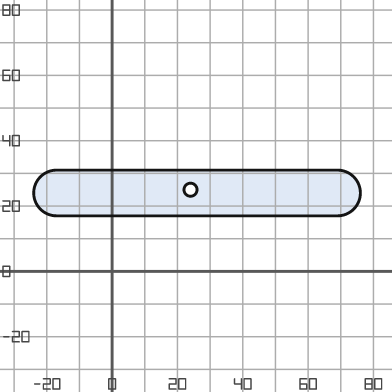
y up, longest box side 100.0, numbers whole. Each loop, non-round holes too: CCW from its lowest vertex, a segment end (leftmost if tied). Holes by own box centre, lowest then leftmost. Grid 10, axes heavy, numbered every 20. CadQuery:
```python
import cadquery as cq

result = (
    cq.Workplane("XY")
    .moveTo(-17.0, 17.0)
    .lineTo(69.0, 17.0)
    .threePointArc((76.0, 24.0), (69.0, 31.0))
    .lineTo(-17.0, 31.0)
    .threePointArc((-24.0, 24.0), (-17.0, 17.0))
    .close()
    .moveTo(24.0, 25.0)
    .circle(2.0)
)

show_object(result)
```